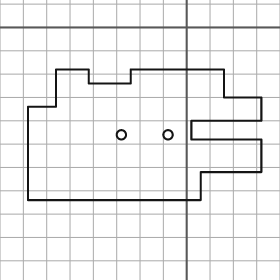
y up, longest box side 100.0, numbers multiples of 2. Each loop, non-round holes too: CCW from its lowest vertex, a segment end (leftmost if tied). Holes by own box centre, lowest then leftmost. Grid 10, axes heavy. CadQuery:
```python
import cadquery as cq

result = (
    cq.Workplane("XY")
    .moveTo(-68.0, -74.0)
    .lineTo(6.0, -74.0)
    .lineTo(6.0, -62.0)
    .lineTo(32.0, -62.0)
    .lineTo(32.0, -48.0)
    .lineTo(2.0, -48.0)
    .lineTo(2.0, -40.0)
    .lineTo(32.0, -40.0)
    .lineTo(32.0, -30.0)
    .lineTo(16.0, -30.0)
    .lineTo(16.0, -18.0)
    .lineTo(-24.0, -18.0)
    .lineTo(-24.0, -24.0)
    .lineTo(-42.0, -24.0)
    .lineTo(-42.0, -18.0)
    .lineTo(-56.0, -18.0)
    .lineTo(-56.0, -34.0)
    .lineTo(-68.0, -34.0)
    .close()
    .moveTo(-28.0, -46.0)
    .circle(2.0)
    .moveTo(-8.0, -46.0)
    .circle(2.0)
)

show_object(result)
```